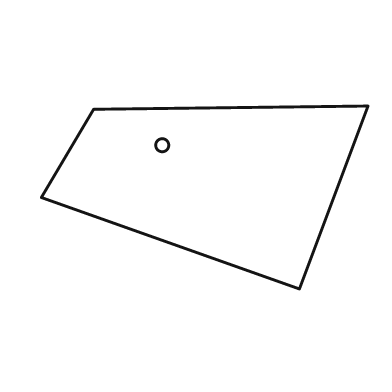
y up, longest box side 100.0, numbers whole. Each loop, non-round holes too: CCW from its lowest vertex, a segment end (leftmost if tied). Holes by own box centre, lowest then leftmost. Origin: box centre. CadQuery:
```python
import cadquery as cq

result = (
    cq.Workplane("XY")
    .moveTo(29.0, -28.0)
    .lineTo(50.0, 28.0)
    .lineTo(-34.0, 27.0)
    .lineTo(-50.0, 0.0)
    .close()
    .moveTo(-13.0, 16.0)
    .circle(2.0)
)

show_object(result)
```